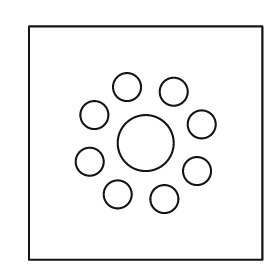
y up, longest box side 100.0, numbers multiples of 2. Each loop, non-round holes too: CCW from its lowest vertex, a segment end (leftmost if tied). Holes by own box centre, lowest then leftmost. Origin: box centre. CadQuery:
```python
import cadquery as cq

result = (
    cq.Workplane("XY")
    .moveTo(-50.0, -50.0)
    .lineTo(50.0, -50.0)
    .lineTo(50.0, 50.0)
    .lineTo(-50.0, 50.0)
    .close()
    .moveTo(8.0, -24.0)
    .circle(6.0)
    .moveTo(-12.0, -22.0)
    .circle(6.0)
    .moveTo(22.0, -12.0)
    .circle(6.0)
    .moveTo(-24.0, -8.0)
    .circle(6.0)
    .moveTo(0.0, 0.0)
    .circle(12.0)
    .moveTo(24.0, 8.0)
    .circle(6.0)
    .moveTo(-22.0, 12.0)
    .circle(6.0)
    .moveTo(12.0, 22.0)
    .circle(6.0)
    .moveTo(-8.0, 24.0)
    .circle(6.0)
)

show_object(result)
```